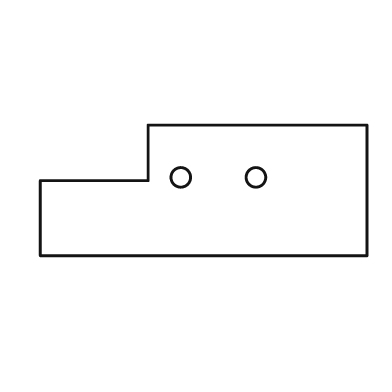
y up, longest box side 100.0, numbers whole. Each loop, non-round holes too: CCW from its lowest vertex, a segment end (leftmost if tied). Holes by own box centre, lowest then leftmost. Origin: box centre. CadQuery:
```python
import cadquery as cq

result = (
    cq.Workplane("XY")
    .moveTo(-50.0, -20.0)
    .lineTo(50.0, -20.0)
    .lineTo(50.0, 20.0)
    .lineTo(-17.0, 20.0)
    .lineTo(-17.0, 3.0)
    .lineTo(-50.0, 3.0)
    .close()
    .moveTo(-7.0, 4.0)
    .circle(3.0)
    .moveTo(16.0, 4.0)
    .circle(3.0)
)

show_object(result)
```